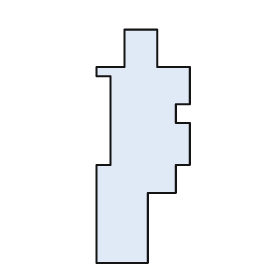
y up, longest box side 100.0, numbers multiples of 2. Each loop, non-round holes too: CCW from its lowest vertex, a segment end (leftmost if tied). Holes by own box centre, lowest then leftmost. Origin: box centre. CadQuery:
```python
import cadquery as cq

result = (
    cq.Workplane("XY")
    .moveTo(-20.0, -50.0)
    .lineTo(2.0, -50.0)
    .lineTo(2.0, -20.0)
    .lineTo(14.0, -20.0)
    .lineTo(14.0, -8.0)
    .lineTo(20.0, -8.0)
    .lineTo(20.0, 10.0)
    .lineTo(14.0, 10.0)
    .lineTo(14.0, 18.0)
    .lineTo(20.0, 18.0)
    .lineTo(20.0, 34.0)
    .lineTo(6.0, 34.0)
    .lineTo(6.0, 50.0)
    .lineTo(-8.0, 50.0)
    .lineTo(-8.0, 34.0)
    .lineTo(-20.0, 34.0)
    .lineTo(-20.0, 30.0)
    .lineTo(-14.0, 30.0)
    .lineTo(-14.0, -8.0)
    .lineTo(-20.0, -8.0)
    .close()
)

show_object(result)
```